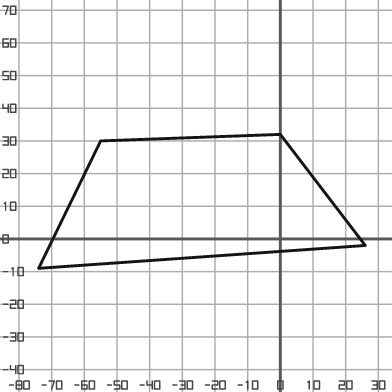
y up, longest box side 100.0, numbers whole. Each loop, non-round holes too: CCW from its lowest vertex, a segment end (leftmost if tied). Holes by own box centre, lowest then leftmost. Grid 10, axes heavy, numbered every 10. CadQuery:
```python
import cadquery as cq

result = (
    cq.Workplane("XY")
    .moveTo(-74.0, -9.0)
    .lineTo(26.0, -2.0)
    .lineTo(0.0, 32.0)
    .lineTo(-55.0, 30.0)
    .close()
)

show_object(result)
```